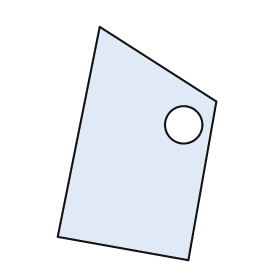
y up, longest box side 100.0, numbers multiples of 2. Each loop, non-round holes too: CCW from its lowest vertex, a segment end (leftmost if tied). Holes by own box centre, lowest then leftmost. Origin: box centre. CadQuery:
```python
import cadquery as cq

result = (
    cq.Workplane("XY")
    .moveTo(22.0, -50.0)
    .lineTo(34.0, 18.0)
    .lineTo(-16.0, 50.0)
    .lineTo(-34.0, -40.0)
    .close()
    .moveTo(20.0, 8.0)
    .circle(8.0)
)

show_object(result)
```